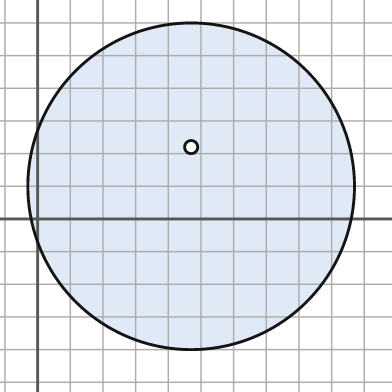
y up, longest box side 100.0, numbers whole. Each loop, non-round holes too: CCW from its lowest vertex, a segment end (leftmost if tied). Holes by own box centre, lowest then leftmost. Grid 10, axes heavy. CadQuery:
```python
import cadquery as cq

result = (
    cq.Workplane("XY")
    .moveTo(47.0, 10.0)
    .circle(50.0)
    .moveTo(47.0, 22.0)
    .circle(2.0)
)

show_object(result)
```